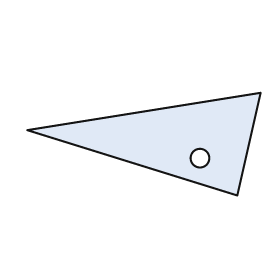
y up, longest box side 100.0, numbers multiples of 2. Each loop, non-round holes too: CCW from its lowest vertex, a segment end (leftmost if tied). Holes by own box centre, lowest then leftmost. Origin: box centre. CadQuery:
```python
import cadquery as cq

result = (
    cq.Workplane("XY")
    .moveTo(40.0, -22.0)
    .lineTo(50.0, 22.0)
    .lineTo(-50.0, 6.0)
    .close()
    .moveTo(24.0, -6.0)
    .circle(4.0)
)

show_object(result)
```